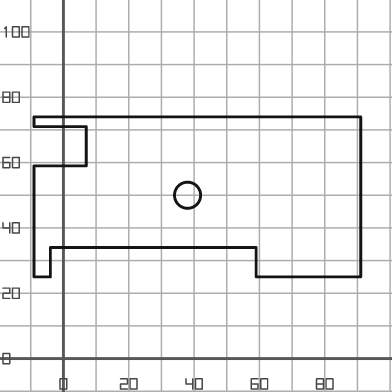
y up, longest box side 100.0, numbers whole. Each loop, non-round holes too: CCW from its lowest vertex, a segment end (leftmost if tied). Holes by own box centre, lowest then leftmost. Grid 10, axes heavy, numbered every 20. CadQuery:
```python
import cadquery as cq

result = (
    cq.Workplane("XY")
    .moveTo(-9.0, 25.0)
    .lineTo(-4.0, 25.0)
    .lineTo(-4.0, 34.0)
    .lineTo(59.0, 34.0)
    .lineTo(59.0, 25.0)
    .lineTo(91.0, 25.0)
    .lineTo(91.0, 74.0)
    .lineTo(-9.0, 74.0)
    .lineTo(-9.0, 71.0)
    .lineTo(7.0, 71.0)
    .lineTo(7.0, 59.0)
    .lineTo(-9.0, 59.0)
    .close()
    .moveTo(38.0, 50.0)
    .circle(4.0)
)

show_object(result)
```